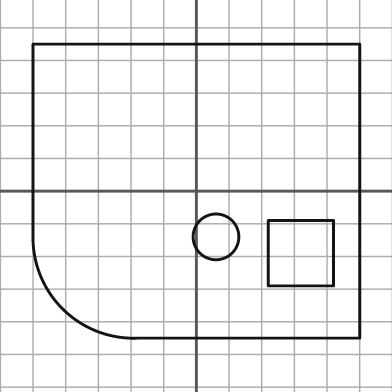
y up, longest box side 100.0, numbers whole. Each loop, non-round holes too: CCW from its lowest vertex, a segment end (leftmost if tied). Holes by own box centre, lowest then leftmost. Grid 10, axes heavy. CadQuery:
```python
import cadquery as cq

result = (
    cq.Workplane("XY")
    .moveTo(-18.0, -45.0)
    .lineTo(50.0, -45.0)
    .lineTo(50.0, 45.0)
    .lineTo(-50.0, 45.0)
    .lineTo(-50.0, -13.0)
    .threePointArc((-41.0, -36.0), (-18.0, -45.0))
    .close()
    .moveTo(22.0, -29.0)
    .lineTo(42.0, -29.0)
    .lineTo(42.0, -9.0)
    .lineTo(22.0, -9.0)
    .close()
    .moveTo(6.0, -14.0)
    .circle(7.0)
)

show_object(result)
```